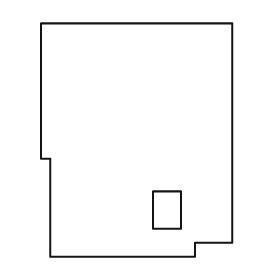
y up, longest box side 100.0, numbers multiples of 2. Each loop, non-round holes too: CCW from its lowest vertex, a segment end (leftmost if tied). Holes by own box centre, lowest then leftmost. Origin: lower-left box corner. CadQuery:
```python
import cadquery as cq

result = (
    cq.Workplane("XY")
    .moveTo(4.0, 0.0)
    .lineTo(66.0, 0.0)
    .lineTo(66.0, 6.0)
    .lineTo(82.0, 6.0)
    .lineTo(82.0, 100.0)
    .lineTo(0.0, 100.0)
    .lineTo(0.0, 42.0)
    .lineTo(4.0, 42.0)
    .close()
    .moveTo(48.0, 12.0)
    .lineTo(60.0, 12.0)
    .lineTo(60.0, 28.0)
    .lineTo(48.0, 28.0)
    .close()
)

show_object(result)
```